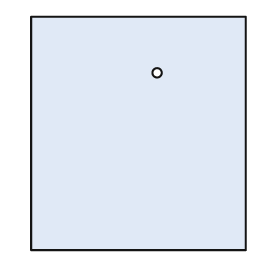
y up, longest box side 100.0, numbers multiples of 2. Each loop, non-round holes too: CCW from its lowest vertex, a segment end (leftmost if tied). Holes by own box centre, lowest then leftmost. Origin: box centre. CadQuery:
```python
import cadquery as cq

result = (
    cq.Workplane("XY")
    .moveTo(-46.0, -50.0)
    .lineTo(46.0, -50.0)
    .lineTo(46.0, 50.0)
    .lineTo(-46.0, 50.0)
    .close()
    .moveTo(8.0, 26.0)
    .circle(2.0)
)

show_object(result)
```